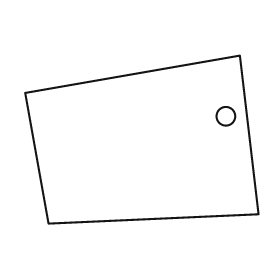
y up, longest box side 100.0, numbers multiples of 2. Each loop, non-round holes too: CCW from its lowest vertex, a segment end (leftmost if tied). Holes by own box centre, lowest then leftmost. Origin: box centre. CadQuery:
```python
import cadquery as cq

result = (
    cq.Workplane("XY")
    .moveTo(-40.0, -36.0)
    .lineTo(50.0, -32.0)
    .lineTo(42.0, 36.0)
    .lineTo(-50.0, 20.0)
    .close()
    .moveTo(36.0, 10.0)
    .circle(4.0)
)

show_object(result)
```